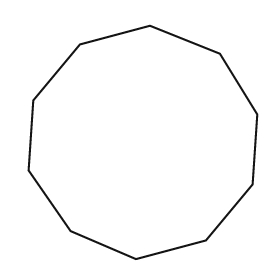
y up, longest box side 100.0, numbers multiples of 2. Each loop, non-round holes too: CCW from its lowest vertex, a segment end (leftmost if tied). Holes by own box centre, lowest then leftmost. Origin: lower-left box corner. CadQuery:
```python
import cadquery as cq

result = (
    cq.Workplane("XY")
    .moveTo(46.0, 0.0)
    .lineTo(76.0, 8.0)
    .lineTo(96.0, 32.0)
    .lineTo(98.0, 62.0)
    .lineTo(82.0, 88.0)
    .lineTo(52.0, 100.0)
    .lineTo(22.0, 92.0)
    .lineTo(2.0, 68.0)
    .lineTo(0.0, 38.0)
    .lineTo(18.0, 12.0)
    .close()
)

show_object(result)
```